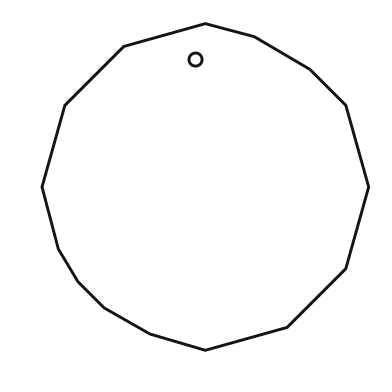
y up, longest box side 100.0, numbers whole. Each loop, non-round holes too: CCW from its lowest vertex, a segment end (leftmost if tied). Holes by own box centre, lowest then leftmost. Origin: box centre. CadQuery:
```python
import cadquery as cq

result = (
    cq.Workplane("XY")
    .moveTo(0.0, -50.0)
    .lineTo(25.0, -43.0)
    .lineTo(43.0, -25.0)
    .lineTo(50.0, 0.0)
    .lineTo(43.0, 25.0)
    .lineTo(32.0, 36.0)
    .lineTo(15.0, 46.0)
    .lineTo(0.0, 50.0)
    .lineTo(-25.0, 43.0)
    .lineTo(-43.0, 25.0)
    .lineTo(-50.0, 0.0)
    .lineTo(-45.0, -19.0)
    .lineTo(-39.0, -29.0)
    .lineTo(-31.0, -37.0)
    .lineTo(-17.0, -45.0)
    .close()
    .moveTo(-3.0, 39.0)
    .circle(2.0)
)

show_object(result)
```